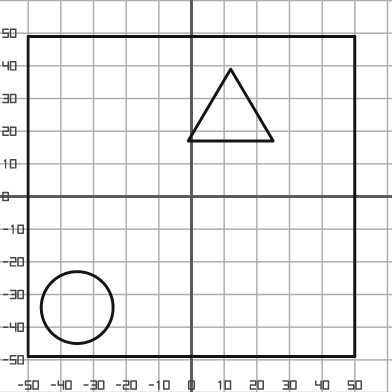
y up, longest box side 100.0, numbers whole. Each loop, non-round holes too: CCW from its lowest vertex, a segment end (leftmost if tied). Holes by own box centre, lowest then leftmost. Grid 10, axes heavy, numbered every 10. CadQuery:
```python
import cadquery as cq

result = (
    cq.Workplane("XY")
    .moveTo(-50.0, -49.0)
    .lineTo(50.0, -49.0)
    .lineTo(50.0, 49.0)
    .lineTo(-50.0, 49.0)
    .close()
    .moveTo(-35.0, -34.0)
    .circle(11.0)
    .moveTo(-1.0, 17.0)
    .lineTo(25.0, 17.0)
    .lineTo(12.0, 39.0)
    .close()
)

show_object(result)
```